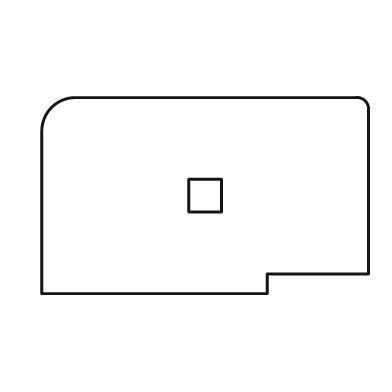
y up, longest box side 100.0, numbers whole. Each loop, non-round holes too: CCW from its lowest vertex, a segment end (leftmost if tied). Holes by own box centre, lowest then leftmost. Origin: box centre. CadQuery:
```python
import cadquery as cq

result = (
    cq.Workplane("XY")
    .moveTo(-50.0, -30.0)
    .lineTo(19.0, -30.0)
    .lineTo(19.0, -24.0)
    .lineTo(50.0, -24.0)
    .lineTo(50.0, 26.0)
    .threePointArc((49.0, 29.0), (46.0, 30.0))
    .lineTo(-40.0, 30.0)
    .threePointArc((-47.0, 27.0), (-50.0, 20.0))
    .close()
    .moveTo(-5.0, -5.0)
    .lineTo(5.0, -5.0)
    .lineTo(5.0, 5.0)
    .lineTo(-5.0, 5.0)
    .close()
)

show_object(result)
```